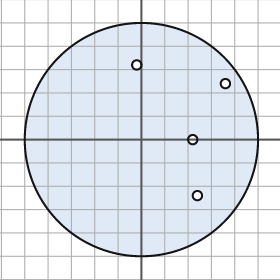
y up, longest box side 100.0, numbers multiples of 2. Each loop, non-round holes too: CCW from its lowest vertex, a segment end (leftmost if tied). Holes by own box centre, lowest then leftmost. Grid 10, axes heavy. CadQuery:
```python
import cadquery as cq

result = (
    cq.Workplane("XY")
    .moveTo(0.0, 0.0)
    .circle(50.0)
    .moveTo(24.0, -24.0)
    .circle(2.0)
    .moveTo(22.0, 0.0)
    .circle(2.0)
    .moveTo(36.0, 24.0)
    .circle(2.0)
    .moveTo(-2.0, 32.0)
    .circle(2.0)
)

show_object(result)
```